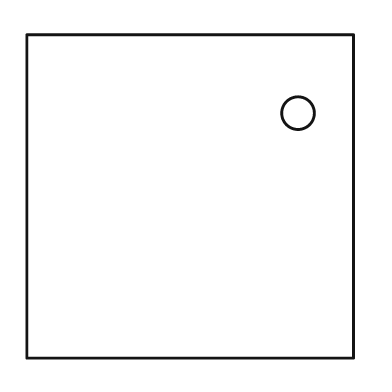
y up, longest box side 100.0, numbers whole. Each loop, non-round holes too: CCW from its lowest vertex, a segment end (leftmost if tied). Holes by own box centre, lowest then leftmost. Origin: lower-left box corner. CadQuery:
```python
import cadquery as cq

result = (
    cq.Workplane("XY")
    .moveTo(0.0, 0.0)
    .lineTo(100.0, 0.0)
    .lineTo(100.0, 99.0)
    .lineTo(0.0, 99.0)
    .close()
    .moveTo(83.0, 75.0)
    .circle(5.0)
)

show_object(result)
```